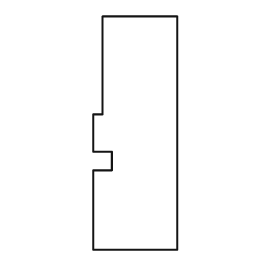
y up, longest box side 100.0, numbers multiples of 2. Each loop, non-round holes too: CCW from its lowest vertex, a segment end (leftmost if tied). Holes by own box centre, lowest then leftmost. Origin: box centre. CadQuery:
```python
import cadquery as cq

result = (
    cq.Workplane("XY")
    .moveTo(-18.0, -50.0)
    .lineTo(18.0, -50.0)
    .lineTo(18.0, 50.0)
    .lineTo(-14.0, 50.0)
    .lineTo(-14.0, 8.0)
    .lineTo(-18.0, 8.0)
    .lineTo(-18.0, -8.0)
    .lineTo(-10.0, -8.0)
    .lineTo(-10.0, -16.0)
    .lineTo(-18.0, -16.0)
    .close()
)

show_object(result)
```